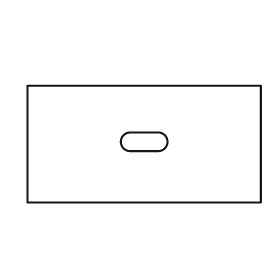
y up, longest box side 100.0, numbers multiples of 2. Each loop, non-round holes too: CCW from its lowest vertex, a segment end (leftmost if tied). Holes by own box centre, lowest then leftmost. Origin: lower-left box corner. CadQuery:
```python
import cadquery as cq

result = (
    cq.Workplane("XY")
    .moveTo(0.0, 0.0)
    .lineTo(100.0, 0.0)
    .lineTo(100.0, 50.0)
    .lineTo(0.0, 50.0)
    .close()
    .moveTo(44.0, 22.0)
    .lineTo(56.0, 22.0)
    .threePointArc((60.0, 26.0), (56.0, 30.0))
    .lineTo(44.0, 30.0)
    .threePointArc((40.0, 26.0), (44.0, 22.0))
    .close()
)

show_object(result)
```